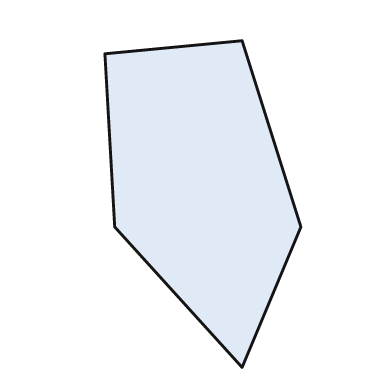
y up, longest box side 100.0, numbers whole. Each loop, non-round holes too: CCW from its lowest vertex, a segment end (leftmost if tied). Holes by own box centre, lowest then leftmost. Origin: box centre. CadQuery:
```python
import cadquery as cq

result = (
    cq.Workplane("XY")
    .moveTo(12.0, -50.0)
    .lineTo(30.0, -7.0)
    .lineTo(12.0, 50.0)
    .lineTo(-30.0, 46.0)
    .lineTo(-27.0, -7.0)
    .close()
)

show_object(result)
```